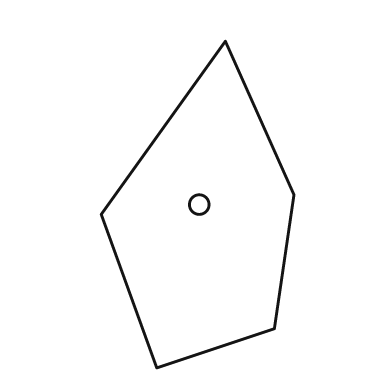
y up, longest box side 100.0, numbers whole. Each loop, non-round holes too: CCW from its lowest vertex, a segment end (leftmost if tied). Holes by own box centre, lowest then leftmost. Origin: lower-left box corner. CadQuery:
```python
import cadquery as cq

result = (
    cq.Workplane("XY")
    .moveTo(17.0, 0.0)
    .lineTo(53.0, 12.0)
    .lineTo(59.0, 53.0)
    .lineTo(38.0, 100.0)
    .lineTo(0.0, 47.0)
    .close()
    .moveTo(30.0, 50.0)
    .circle(3.0)
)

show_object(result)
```